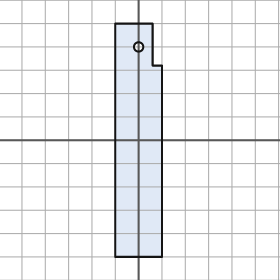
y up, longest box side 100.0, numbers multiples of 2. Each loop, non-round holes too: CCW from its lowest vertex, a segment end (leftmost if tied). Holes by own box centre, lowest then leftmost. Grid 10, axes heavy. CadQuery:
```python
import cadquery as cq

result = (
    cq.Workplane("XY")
    .moveTo(-10.0, -50.0)
    .lineTo(10.0, -50.0)
    .lineTo(10.0, 32.0)
    .lineTo(6.0, 32.0)
    .lineTo(6.0, 50.0)
    .lineTo(-10.0, 50.0)
    .close()
    .moveTo(0.0, 40.0)
    .circle(2.0)
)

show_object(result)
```